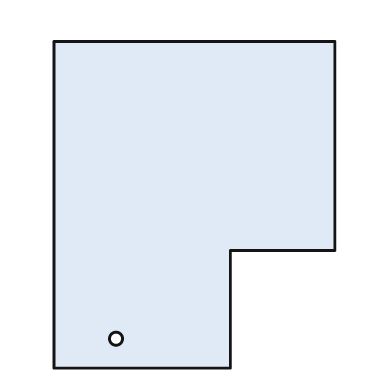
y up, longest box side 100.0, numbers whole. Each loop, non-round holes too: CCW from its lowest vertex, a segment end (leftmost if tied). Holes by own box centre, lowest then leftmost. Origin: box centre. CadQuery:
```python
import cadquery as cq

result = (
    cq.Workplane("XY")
    .moveTo(-43.0, -50.0)
    .lineTo(11.0, -50.0)
    .lineTo(11.0, -14.0)
    .lineTo(43.0, -14.0)
    .lineTo(43.0, 50.0)
    .lineTo(-43.0, 50.0)
    .close()
    .moveTo(-24.0, -41.0)
    .circle(2.0)
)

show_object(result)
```